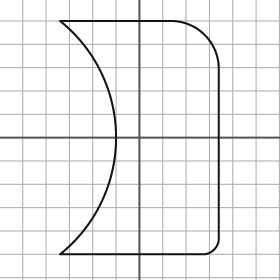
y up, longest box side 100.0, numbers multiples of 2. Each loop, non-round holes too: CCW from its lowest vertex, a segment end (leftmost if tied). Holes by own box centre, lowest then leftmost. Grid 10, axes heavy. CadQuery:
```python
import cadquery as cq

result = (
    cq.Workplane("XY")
    .moveTo(-34.0, -50.0)
    .lineTo(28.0, -50.0)
    .threePointArc((32.0, -48.0), (34.0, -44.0))
    .lineTo(34.0, 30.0)
    .threePointArc((28.0, 44.0), (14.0, 50.0))
    .lineTo(-34.0, 50.0)
    .threePointArc((-10.0, 0.0), (-34.0, -50.0))
    .close()
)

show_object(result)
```